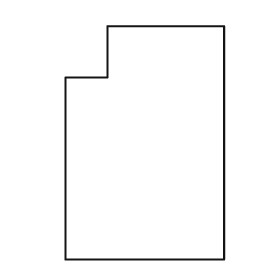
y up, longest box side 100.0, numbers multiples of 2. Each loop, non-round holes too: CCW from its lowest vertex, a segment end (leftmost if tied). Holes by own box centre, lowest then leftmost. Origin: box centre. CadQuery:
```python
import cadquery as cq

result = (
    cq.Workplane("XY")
    .moveTo(-34.0, -50.0)
    .lineTo(34.0, -50.0)
    .lineTo(34.0, 50.0)
    .lineTo(-16.0, 50.0)
    .lineTo(-16.0, 28.0)
    .lineTo(-34.0, 28.0)
    .close()
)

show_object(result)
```